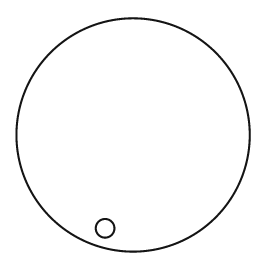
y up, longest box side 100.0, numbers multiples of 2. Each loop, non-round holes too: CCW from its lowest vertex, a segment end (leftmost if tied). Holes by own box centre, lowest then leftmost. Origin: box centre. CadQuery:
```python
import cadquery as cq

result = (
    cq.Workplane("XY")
    .moveTo(0.0, 0.0)
    .circle(50.0)
    .moveTo(-12.0, -40.0)
    .circle(4.0)
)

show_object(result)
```